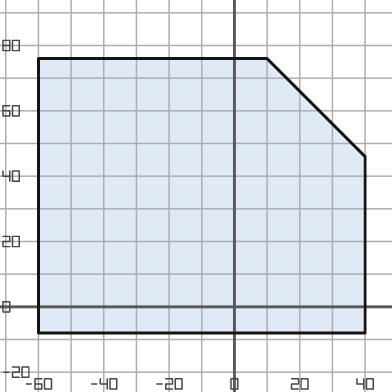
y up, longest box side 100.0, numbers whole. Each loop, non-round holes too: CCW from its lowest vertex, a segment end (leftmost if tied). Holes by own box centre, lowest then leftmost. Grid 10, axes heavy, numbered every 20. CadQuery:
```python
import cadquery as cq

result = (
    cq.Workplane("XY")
    .moveTo(-60.0, -8.0)
    .lineTo(40.0, -8.0)
    .lineTo(40.0, 46.0)
    .lineTo(10.0, 76.0)
    .lineTo(-60.0, 76.0)
    .close()
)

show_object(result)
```